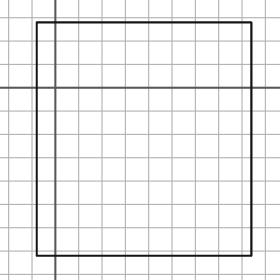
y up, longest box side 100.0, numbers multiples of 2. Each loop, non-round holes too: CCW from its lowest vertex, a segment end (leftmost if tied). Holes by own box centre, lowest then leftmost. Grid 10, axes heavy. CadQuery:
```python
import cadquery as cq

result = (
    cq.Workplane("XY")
    .moveTo(-8.0, -72.0)
    .lineTo(84.0, -72.0)
    .lineTo(84.0, 28.0)
    .lineTo(-8.0, 28.0)
    .close()
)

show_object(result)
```